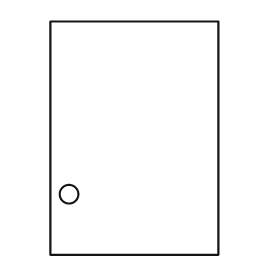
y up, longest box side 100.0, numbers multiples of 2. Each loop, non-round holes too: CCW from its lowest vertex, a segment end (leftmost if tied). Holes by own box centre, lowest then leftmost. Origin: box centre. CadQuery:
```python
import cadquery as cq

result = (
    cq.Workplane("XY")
    .moveTo(-36.0, -50.0)
    .lineTo(36.0, -50.0)
    .lineTo(36.0, 50.0)
    .lineTo(-36.0, 50.0)
    .close()
    .moveTo(-28.0, -24.0)
    .circle(4.0)
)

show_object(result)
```